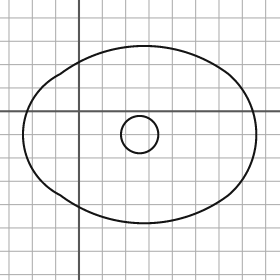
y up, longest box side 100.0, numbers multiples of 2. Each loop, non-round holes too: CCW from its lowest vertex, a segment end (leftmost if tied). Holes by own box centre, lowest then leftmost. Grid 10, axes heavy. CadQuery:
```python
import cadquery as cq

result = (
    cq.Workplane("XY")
    .moveTo(-8.0, -36.0)
    .threePointArc((28.0, -48.0), (64.0, -36.0))
    .threePointArc((76.0, -10.0), (64.0, 16.0))
    .threePointArc((28.0, 28.0), (-8.0, 16.0))
    .threePointArc((-24.0, -10.0), (-8.0, -36.0))
    .close()
    .moveTo(26.0, -10.0)
    .circle(8.0)
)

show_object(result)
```